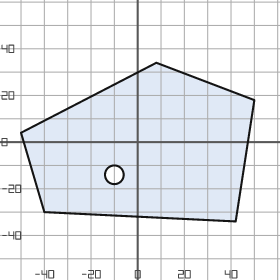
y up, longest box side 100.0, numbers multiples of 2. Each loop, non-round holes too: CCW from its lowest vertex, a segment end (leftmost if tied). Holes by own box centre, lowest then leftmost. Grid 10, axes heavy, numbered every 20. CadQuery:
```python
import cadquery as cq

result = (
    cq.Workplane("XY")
    .moveTo(42.0, -34.0)
    .lineTo(50.0, 18.0)
    .lineTo(8.0, 34.0)
    .lineTo(-50.0, 4.0)
    .lineTo(-40.0, -30.0)
    .close()
    .moveTo(-10.0, -14.0)
    .circle(4.0)
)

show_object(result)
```